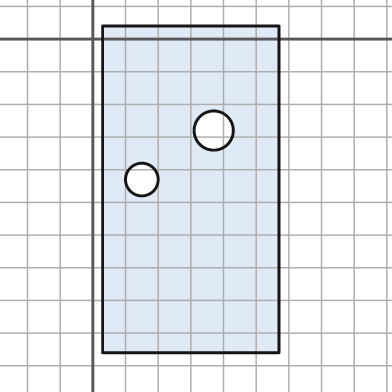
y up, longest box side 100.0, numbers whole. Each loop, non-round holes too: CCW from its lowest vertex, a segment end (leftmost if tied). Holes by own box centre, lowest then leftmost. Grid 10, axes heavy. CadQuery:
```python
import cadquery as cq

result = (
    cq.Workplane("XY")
    .moveTo(3.0, -96.0)
    .lineTo(57.0, -96.0)
    .lineTo(57.0, 4.0)
    .lineTo(3.0, 4.0)
    .close()
    .moveTo(15.0, -43.0)
    .circle(5.0)
    .moveTo(37.0, -28.0)
    .circle(6.0)
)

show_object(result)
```